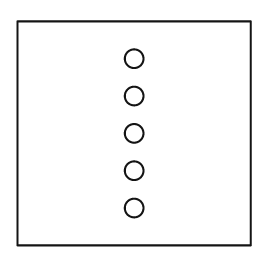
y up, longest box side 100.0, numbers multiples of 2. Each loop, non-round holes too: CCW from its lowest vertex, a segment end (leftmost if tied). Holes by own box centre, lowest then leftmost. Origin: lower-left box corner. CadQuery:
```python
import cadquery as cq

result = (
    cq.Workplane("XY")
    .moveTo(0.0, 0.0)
    .lineTo(100.0, 0.0)
    .lineTo(100.0, 96.0)
    .lineTo(0.0, 96.0)
    .close()
    .moveTo(50.0, 16.0)
    .circle(4.0)
    .moveTo(50.0, 32.0)
    .circle(4.0)
    .moveTo(50.0, 48.0)
    .circle(4.0)
    .moveTo(50.0, 64.0)
    .circle(4.0)
    .moveTo(50.0, 80.0)
    .circle(4.0)
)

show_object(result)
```